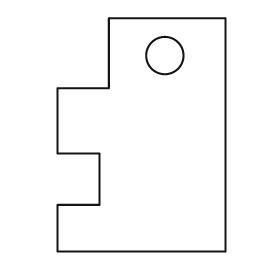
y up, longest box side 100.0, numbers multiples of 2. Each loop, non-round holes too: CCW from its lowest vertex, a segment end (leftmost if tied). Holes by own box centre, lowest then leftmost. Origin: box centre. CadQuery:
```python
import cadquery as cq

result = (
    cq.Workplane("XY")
    .moveTo(-36.0, -50.0)
    .lineTo(36.0, -50.0)
    .lineTo(36.0, 50.0)
    .lineTo(-14.0, 50.0)
    .lineTo(-14.0, 20.0)
    .lineTo(-36.0, 20.0)
    .lineTo(-36.0, -8.0)
    .lineTo(-18.0, -8.0)
    .lineTo(-18.0, -30.0)
    .lineTo(-36.0, -30.0)
    .close()
    .moveTo(10.0, 34.0)
    .circle(8.0)
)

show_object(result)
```